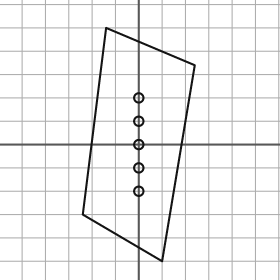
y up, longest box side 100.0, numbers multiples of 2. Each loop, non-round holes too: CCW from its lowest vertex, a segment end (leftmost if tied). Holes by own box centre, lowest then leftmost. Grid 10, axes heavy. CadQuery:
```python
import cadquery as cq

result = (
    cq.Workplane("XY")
    .moveTo(10.0, -50.0)
    .lineTo(24.0, 34.0)
    .lineTo(-14.0, 50.0)
    .lineTo(-24.0, -30.0)
    .close()
    .moveTo(0.0, -20.0)
    .circle(2.0)
    .moveTo(0.0, -10.0)
    .circle(2.0)
    .moveTo(0.0, 0.0)
    .circle(2.0)
    .moveTo(0.0, 10.0)
    .circle(2.0)
    .moveTo(0.0, 20.0)
    .circle(2.0)
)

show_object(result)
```